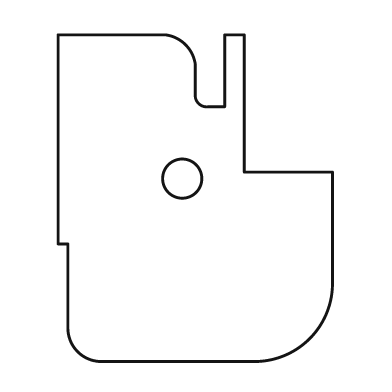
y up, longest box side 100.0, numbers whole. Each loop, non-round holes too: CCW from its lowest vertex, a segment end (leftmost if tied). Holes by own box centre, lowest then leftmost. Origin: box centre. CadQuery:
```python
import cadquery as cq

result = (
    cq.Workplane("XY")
    .moveTo(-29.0, -50.0)
    .lineTo(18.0, -50.0)
    .threePointArc((35.0, -43.0), (42.0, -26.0))
    .lineTo(42.0, 8.0)
    .lineTo(15.0, 8.0)
    .lineTo(15.0, 50.0)
    .lineTo(9.0, 50.0)
    .lineTo(9.0, 28.0)
    .lineTo(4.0, 28.0)
    .threePointArc((1.0, 29.0), (0.0, 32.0))
    .lineTo(0.0, 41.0)
    .threePointArc((-3.0, 47.0), (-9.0, 50.0))
    .lineTo(-42.0, 50.0)
    .lineTo(-42.0, -14.0)
    .lineTo(-39.0, -14.0)
    .lineTo(-39.0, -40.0)
    .threePointArc((-36.0, -47.0), (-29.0, -50.0))
    .close()
    .moveTo(-4.0, 6.0)
    .circle(6.0)
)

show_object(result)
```